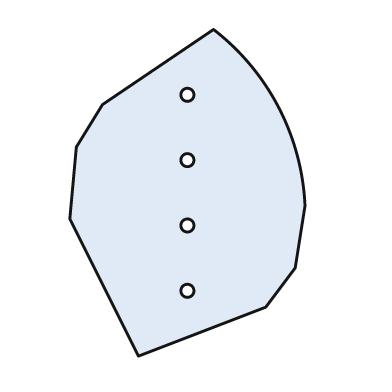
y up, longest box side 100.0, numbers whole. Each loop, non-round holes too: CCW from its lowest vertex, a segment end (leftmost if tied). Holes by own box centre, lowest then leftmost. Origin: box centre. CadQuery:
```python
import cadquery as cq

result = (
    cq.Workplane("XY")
    .moveTo(-15.0, -50.0)
    .lineTo(24.0, -35.0)
    .lineTo(33.0, -23.0)
    .lineTo(36.0, -4.0)
    .threePointArc((28.0, 26.0), (8.0, 50.0))
    .lineTo(-26.0, 27.0)
    .lineTo(-34.0, 14.0)
    .lineTo(-36.0, -8.0)
    .close()
    .moveTo(0.0, -30.0)
    .circle(2.0)
    .moveTo(0.0, -10.0)
    .circle(2.0)
    .moveTo(0.0, 10.0)
    .circle(2.0)
    .moveTo(0.0, 30.0)
    .circle(2.0)
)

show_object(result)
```